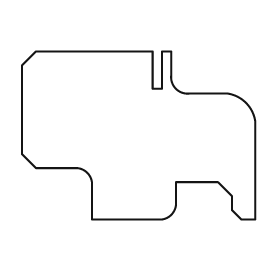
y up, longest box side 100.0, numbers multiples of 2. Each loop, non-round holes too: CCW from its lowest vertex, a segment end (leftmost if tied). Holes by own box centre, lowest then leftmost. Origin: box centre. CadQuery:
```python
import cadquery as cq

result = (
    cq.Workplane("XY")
    .moveTo(-20.0, -36.0)
    .lineTo(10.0, -36.0)
    .threePointArc((14.0, -34.0), (16.0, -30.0))
    .lineTo(16.0, -20.0)
    .lineTo(34.0, -20.0)
    .lineTo(40.0, -26.0)
    .lineTo(40.0, -32.0)
    .lineTo(44.0, -36.0)
    .lineTo(50.0, -36.0)
    .lineTo(50.0, 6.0)
    .threePointArc((46.0, 14.0), (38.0, 18.0))
    .lineTo(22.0, 18.0)
    .threePointArc((16.0, 20.0), (14.0, 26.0))
    .lineTo(14.0, 36.0)
    .lineTo(10.0, 36.0)
    .lineTo(10.0, 20.0)
    .lineTo(6.0, 20.0)
    .lineTo(6.0, 36.0)
    .lineTo(-44.0, 36.0)
    .lineTo(-50.0, 30.0)
    .lineTo(-50.0, -8.0)
    .lineTo(-44.0, -14.0)
    .lineTo(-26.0, -14.0)
    .threePointArc((-22.0, -16.0), (-20.0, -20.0))
    .close()
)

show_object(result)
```